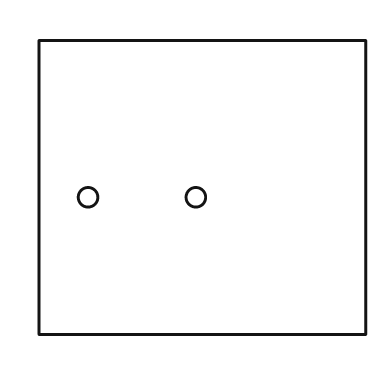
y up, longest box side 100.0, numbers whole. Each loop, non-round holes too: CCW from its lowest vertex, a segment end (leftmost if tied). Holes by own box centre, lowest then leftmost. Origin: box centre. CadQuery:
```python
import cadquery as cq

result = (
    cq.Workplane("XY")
    .moveTo(-50.0, -45.0)
    .lineTo(50.0, -45.0)
    .lineTo(50.0, 45.0)
    .lineTo(-50.0, 45.0)
    .close()
    .moveTo(-35.0, -3.0)
    .circle(3.0)
    .moveTo(-2.0, -3.0)
    .circle(3.0)
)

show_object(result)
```